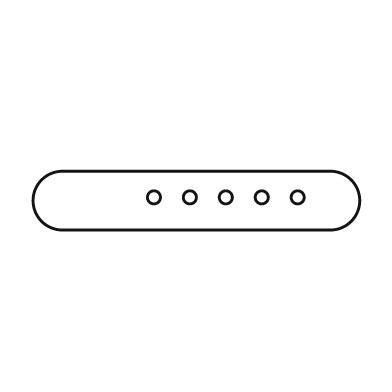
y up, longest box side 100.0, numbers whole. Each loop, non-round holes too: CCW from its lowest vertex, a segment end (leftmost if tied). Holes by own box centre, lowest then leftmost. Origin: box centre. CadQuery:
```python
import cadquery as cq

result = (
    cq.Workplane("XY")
    .moveTo(-41.0, -9.0)
    .lineTo(41.0, -9.0)
    .threePointArc((50.0, 0.0), (41.0, 9.0))
    .lineTo(-41.0, 9.0)
    .threePointArc((-50.0, 0.0), (-41.0, -9.0))
    .close()
    .moveTo(-13.0, 1.0)
    .circle(2.0)
    .moveTo(-2.0, 1.0)
    .circle(2.0)
    .moveTo(9.0, 1.0)
    .circle(2.0)
    .moveTo(20.0, 1.0)
    .circle(2.0)
    .moveTo(31.0, 1.0)
    .circle(2.0)
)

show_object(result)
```